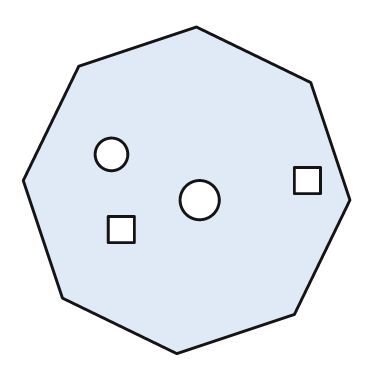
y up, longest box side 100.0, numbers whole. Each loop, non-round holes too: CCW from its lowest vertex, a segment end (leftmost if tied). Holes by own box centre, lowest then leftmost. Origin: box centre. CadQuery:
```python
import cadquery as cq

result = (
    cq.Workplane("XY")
    .moveTo(-3.0, -50.0)
    .lineTo(33.0, -38.0)
    .lineTo(50.0, -3.0)
    .lineTo(38.0, 33.0)
    .lineTo(3.0, 50.0)
    .lineTo(-33.0, 38.0)
    .lineTo(-50.0, 3.0)
    .lineTo(-38.0, -33.0)
    .close()
    .moveTo(-24.0, -16.0)
    .lineTo(-16.0, -16.0)
    .lineTo(-16.0, -8.0)
    .lineTo(-24.0, -8.0)
    .close()
    .moveTo(4.0, -3.0)
    .circle(6.0)
    .moveTo(33.0, -1.0)
    .lineTo(41.0, -1.0)
    .lineTo(41.0, 7.0)
    .lineTo(33.0, 7.0)
    .close()
    .moveTo(-23.0, 11.0)
    .circle(5.0)
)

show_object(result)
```